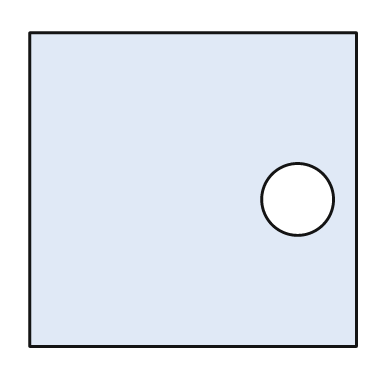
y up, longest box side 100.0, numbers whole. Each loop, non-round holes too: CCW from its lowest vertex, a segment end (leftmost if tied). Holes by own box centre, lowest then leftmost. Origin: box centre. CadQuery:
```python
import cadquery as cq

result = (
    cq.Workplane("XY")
    .moveTo(-50.0, -48.0)
    .lineTo(50.0, -48.0)
    .lineTo(50.0, 48.0)
    .lineTo(-50.0, 48.0)
    .close()
    .moveTo(32.0, -3.0)
    .circle(11.0)
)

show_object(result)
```